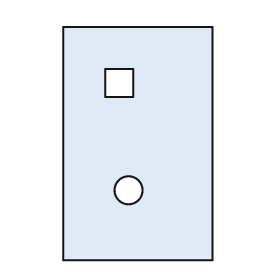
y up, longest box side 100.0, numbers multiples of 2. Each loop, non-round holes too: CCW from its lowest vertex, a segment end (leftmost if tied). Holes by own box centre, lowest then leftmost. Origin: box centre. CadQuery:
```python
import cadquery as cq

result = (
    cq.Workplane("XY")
    .moveTo(-32.0, -50.0)
    .lineTo(32.0, -50.0)
    .lineTo(32.0, 50.0)
    .lineTo(-32.0, 50.0)
    .close()
    .moveTo(-4.0, -20.0)
    .circle(6.0)
    .moveTo(-14.0, 20.0)
    .lineTo(-2.0, 20.0)
    .lineTo(-2.0, 32.0)
    .lineTo(-14.0, 32.0)
    .close()
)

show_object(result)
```